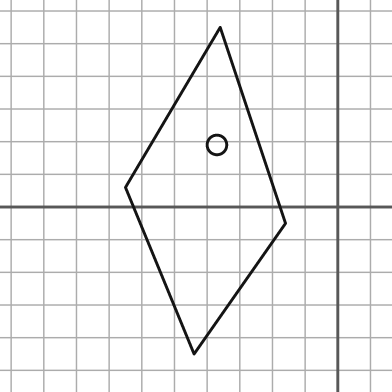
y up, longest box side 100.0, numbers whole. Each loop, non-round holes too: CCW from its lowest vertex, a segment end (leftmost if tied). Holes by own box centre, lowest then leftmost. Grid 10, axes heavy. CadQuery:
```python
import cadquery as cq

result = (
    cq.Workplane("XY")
    .moveTo(-44.0, -45.0)
    .lineTo(-16.0, -5.0)
    .lineTo(-36.0, 55.0)
    .lineTo(-65.0, 6.0)
    .close()
    .moveTo(-37.0, 19.0)
    .circle(3.0)
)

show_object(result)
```